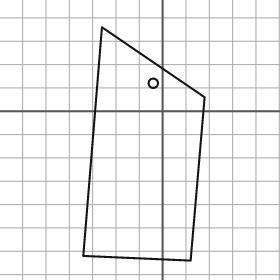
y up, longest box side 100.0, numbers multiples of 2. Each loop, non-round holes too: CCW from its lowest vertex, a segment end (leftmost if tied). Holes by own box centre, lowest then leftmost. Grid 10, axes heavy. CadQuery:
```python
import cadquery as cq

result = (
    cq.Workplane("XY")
    .moveTo(12.0, -64.0)
    .lineTo(18.0, 6.0)
    .lineTo(-26.0, 36.0)
    .lineTo(-34.0, -62.0)
    .close()
    .moveTo(-4.0, 12.0)
    .circle(2.0)
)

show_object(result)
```